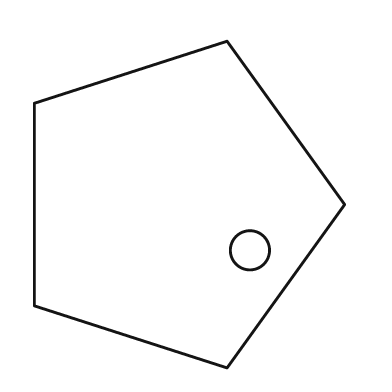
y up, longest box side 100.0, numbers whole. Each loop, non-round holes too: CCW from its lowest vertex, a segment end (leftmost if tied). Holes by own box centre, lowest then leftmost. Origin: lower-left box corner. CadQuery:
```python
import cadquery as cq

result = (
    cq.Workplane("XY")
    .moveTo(59.0, 0.0)
    .lineTo(95.0, 50.0)
    .lineTo(59.0, 100.0)
    .lineTo(0.0, 81.0)
    .lineTo(0.0, 19.0)
    .close()
    .moveTo(66.0, 36.0)
    .circle(6.0)
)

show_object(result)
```